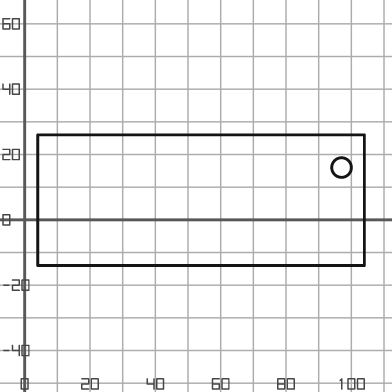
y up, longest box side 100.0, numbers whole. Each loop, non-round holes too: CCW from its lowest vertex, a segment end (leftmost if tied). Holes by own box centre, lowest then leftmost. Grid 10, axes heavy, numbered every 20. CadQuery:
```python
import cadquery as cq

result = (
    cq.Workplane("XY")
    .moveTo(4.0, -14.0)
    .lineTo(104.0, -14.0)
    .lineTo(104.0, 26.0)
    .lineTo(4.0, 26.0)
    .close()
    .moveTo(97.0, 16.0)
    .circle(3.0)
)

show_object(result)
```